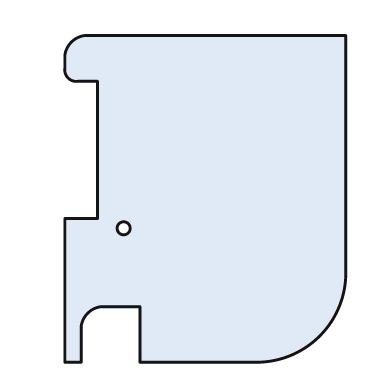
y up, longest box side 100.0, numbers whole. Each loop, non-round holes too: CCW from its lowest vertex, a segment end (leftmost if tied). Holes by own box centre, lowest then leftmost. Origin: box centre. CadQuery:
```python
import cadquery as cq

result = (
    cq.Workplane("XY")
    .moveTo(-43.0, -50.0)
    .lineTo(-38.0, -50.0)
    .lineTo(-38.0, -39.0)
    .threePointArc((-36.0, -35.0), (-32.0, -33.0))
    .lineTo(-20.0, -33.0)
    .lineTo(-20.0, -50.0)
    .lineTo(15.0, -50.0)
    .threePointArc((35.0, -42.0), (43.0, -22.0))
    .lineTo(43.0, 50.0)
    .lineTo(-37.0, 50.0)
    .threePointArc((-41.0, 48.0), (-43.0, 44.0))
    .lineTo(-43.0, 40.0)
    .threePointArc((-42.0, 37.0), (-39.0, 36.0))
    .lineTo(-33.0, 36.0)
    .lineTo(-33.0, -6.0)
    .lineTo(-43.0, -6.0)
    .close()
    .moveTo(-25.0, -9.0)
    .circle(2.0)
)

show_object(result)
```